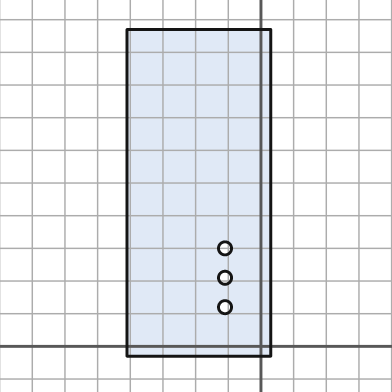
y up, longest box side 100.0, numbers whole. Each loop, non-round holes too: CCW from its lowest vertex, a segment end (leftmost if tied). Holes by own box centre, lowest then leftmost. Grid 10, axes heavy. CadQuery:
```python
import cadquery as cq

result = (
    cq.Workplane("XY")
    .moveTo(-41.0, -3.0)
    .lineTo(3.0, -3.0)
    .lineTo(3.0, 97.0)
    .lineTo(-41.0, 97.0)
    .close()
    .moveTo(-11.0, 12.0)
    .circle(2.0)
    .moveTo(-11.0, 21.0)
    .circle(2.0)
    .moveTo(-11.0, 30.0)
    .circle(2.0)
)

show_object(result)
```